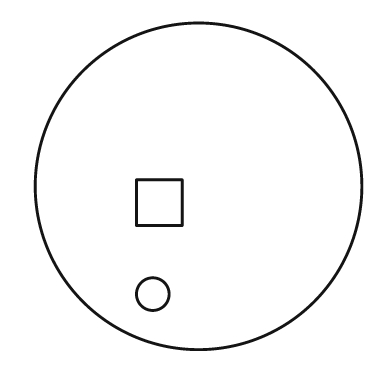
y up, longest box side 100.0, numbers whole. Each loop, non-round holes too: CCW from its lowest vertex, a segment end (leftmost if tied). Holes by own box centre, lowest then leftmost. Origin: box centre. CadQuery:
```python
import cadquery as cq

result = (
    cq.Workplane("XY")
    .moveTo(0.0, 0.0)
    .circle(50.0)
    .moveTo(-14.0, -33.0)
    .circle(5.0)
    .moveTo(-19.0, -12.0)
    .lineTo(-5.0, -12.0)
    .lineTo(-5.0, 2.0)
    .lineTo(-19.0, 2.0)
    .close()
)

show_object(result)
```